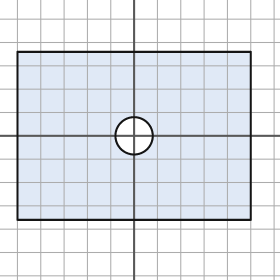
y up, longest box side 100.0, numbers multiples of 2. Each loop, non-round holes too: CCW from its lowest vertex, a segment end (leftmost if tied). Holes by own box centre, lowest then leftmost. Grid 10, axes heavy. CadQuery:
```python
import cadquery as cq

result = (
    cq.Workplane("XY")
    .moveTo(-50.0, -36.0)
    .lineTo(50.0, -36.0)
    .lineTo(50.0, 36.0)
    .lineTo(-50.0, 36.0)
    .close()
    .moveTo(0.0, 0.0)
    .circle(8.0)
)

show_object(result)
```